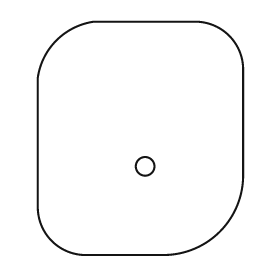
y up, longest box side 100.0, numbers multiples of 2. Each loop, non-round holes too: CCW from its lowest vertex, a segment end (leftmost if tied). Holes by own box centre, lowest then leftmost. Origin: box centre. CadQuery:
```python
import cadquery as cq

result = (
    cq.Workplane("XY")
    .moveTo(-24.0, -50.0)
    .lineTo(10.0, -50.0)
    .threePointArc((34.0, -40.0), (44.0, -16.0))
    .lineTo(44.0, 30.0)
    .threePointArc((38.0, 44.0), (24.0, 50.0))
    .lineTo(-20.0, 50.0)
    .threePointArc((-36.0, 42.0), (-44.0, 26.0))
    .lineTo(-44.0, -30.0)
    .threePointArc((-38.0, -44.0), (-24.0, -50.0))
    .close()
    .moveTo(2.0, -12.0)
    .circle(4.0)
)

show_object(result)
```